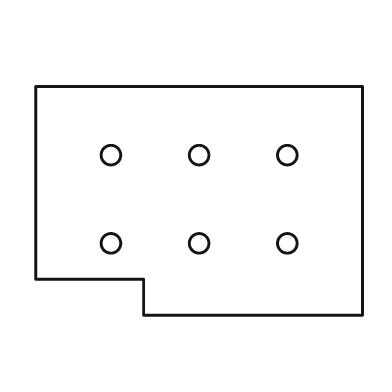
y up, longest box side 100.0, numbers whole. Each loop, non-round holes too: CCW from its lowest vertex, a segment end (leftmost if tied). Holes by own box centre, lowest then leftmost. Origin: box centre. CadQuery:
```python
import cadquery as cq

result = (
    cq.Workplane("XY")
    .moveTo(-17.0, -35.0)
    .lineTo(50.0, -35.0)
    .lineTo(50.0, 35.0)
    .lineTo(-50.0, 35.0)
    .lineTo(-50.0, -24.0)
    .lineTo(-17.0, -24.0)
    .close()
    .moveTo(-27.0, -13.0)
    .circle(3.0)
    .moveTo(0.0, -13.0)
    .circle(3.0)
    .moveTo(27.0, -13.0)
    .circle(3.0)
    .moveTo(-27.0, 14.0)
    .circle(3.0)
    .moveTo(0.0, 14.0)
    .circle(3.0)
    .moveTo(27.0, 14.0)
    .circle(3.0)
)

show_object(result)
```